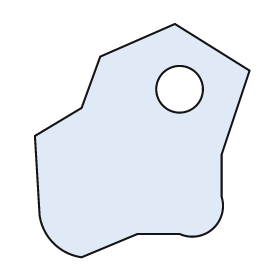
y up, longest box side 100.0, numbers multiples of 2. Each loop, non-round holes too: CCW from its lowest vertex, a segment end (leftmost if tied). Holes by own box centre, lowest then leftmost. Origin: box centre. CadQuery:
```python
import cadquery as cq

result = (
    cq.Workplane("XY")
    .moveTo(-26.0, -50.0)
    .lineTo(-2.0, -40.0)
    .lineTo(16.0, -40.0)
    .threePointArc((30.0, -38.0), (34.0, -24.0))
    .lineTo(34.0, -6.0)
    .lineTo(46.0, 30.0)
    .lineTo(14.0, 50.0)
    .lineTo(-18.0, 36.0)
    .lineTo(-26.0, 14.0)
    .lineTo(-46.0, 2.0)
    .lineTo(-44.0, -32.0)
    .threePointArc((-38.0, -44.0), (-26.0, -50.0))
    .close()
    .moveTo(16.0, 22.0)
    .circle(10.0)
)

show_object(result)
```